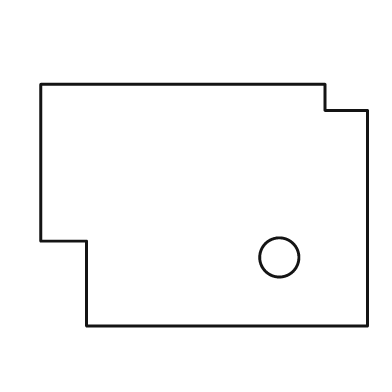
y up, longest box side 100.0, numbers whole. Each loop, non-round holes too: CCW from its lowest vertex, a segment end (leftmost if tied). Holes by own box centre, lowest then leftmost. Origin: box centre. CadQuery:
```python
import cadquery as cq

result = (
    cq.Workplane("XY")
    .moveTo(-36.0, -37.0)
    .lineTo(50.0, -37.0)
    .lineTo(50.0, 29.0)
    .lineTo(37.0, 29.0)
    .lineTo(37.0, 37.0)
    .lineTo(-50.0, 37.0)
    .lineTo(-50.0, -11.0)
    .lineTo(-36.0, -11.0)
    .close()
    .moveTo(23.0, -16.0)
    .circle(6.0)
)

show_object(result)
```